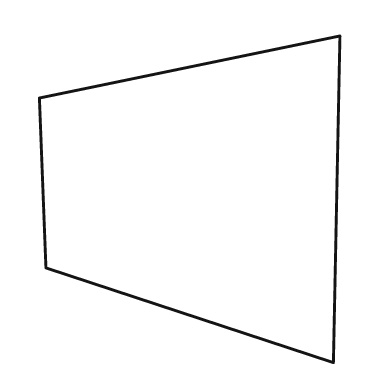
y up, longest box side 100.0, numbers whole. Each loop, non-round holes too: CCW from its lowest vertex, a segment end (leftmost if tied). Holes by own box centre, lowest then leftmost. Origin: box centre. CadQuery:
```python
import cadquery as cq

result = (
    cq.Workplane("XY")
    .moveTo(44.0, -50.0)
    .lineTo(46.0, 50.0)
    .lineTo(-46.0, 31.0)
    .lineTo(-44.0, -21.0)
    .close()
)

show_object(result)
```